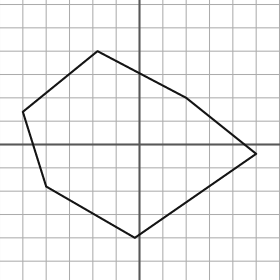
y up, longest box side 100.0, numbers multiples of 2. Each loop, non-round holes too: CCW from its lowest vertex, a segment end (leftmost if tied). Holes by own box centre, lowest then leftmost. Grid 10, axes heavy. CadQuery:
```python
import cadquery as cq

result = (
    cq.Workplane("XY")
    .moveTo(-2.0, -40.0)
    .lineTo(50.0, -4.0)
    .lineTo(20.0, 20.0)
    .lineTo(-18.0, 40.0)
    .lineTo(-50.0, 14.0)
    .lineTo(-40.0, -18.0)
    .close()
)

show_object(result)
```